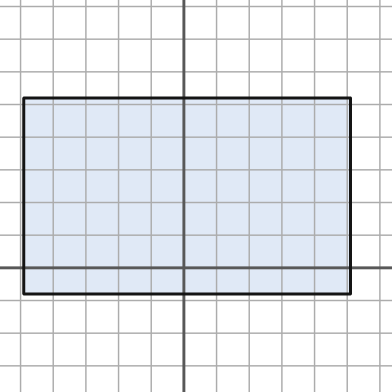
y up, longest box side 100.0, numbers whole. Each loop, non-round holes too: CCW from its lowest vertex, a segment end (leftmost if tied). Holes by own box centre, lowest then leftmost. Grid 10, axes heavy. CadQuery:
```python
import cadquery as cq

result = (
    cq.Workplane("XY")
    .moveTo(-49.0, -8.0)
    .lineTo(51.0, -8.0)
    .lineTo(51.0, 52.0)
    .lineTo(-49.0, 52.0)
    .close()
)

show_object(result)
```